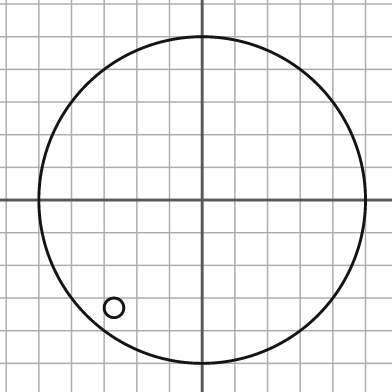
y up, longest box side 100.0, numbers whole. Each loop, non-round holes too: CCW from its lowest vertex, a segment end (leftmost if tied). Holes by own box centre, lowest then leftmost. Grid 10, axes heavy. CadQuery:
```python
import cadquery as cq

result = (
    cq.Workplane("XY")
    .moveTo(0.0, 0.0)
    .circle(50.0)
    .moveTo(-27.0, -33.0)
    .circle(3.0)
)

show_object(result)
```